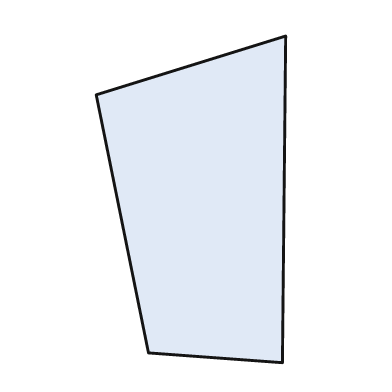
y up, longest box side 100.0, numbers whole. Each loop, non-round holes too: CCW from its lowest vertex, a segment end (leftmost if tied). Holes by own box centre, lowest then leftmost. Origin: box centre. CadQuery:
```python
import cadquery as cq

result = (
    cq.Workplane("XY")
    .moveTo(28.0, -50.0)
    .lineTo(29.0, 50.0)
    .lineTo(-29.0, 32.0)
    .lineTo(-13.0, -47.0)
    .close()
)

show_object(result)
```